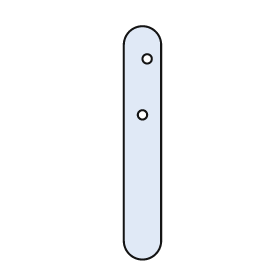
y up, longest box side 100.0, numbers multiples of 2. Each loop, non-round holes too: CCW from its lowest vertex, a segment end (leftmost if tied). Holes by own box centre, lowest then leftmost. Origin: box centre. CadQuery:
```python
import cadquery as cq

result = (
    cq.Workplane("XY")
    .moveTo(-8.0, -42.0)
    .threePointArc((0.0, -50.0), (8.0, -42.0))
    .lineTo(8.0, 42.0)
    .threePointArc((0.0, 50.0), (-8.0, 42.0))
    .close()
    .moveTo(0.0, 12.0)
    .circle(2.0)
    .moveTo(2.0, 36.0)
    .circle(2.0)
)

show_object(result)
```